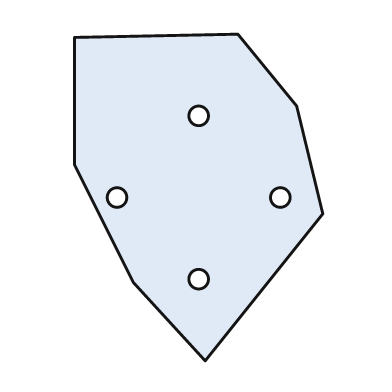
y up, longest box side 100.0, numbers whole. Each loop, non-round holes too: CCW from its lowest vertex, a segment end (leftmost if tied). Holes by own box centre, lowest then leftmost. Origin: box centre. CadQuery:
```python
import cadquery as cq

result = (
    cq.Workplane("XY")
    .moveTo(2.0, -50.0)
    .lineTo(38.0, -5.0)
    .lineTo(30.0, 28.0)
    .lineTo(12.0, 50.0)
    .lineTo(-38.0, 49.0)
    .lineTo(-38.0, 10.0)
    .lineTo(-20.0, -26.0)
    .close()
    .moveTo(0.0, -25.0)
    .circle(3.0)
    .moveTo(-25.0, 0.0)
    .circle(3.0)
    .moveTo(25.0, 0.0)
    .circle(3.0)
    .moveTo(0.0, 25.0)
    .circle(3.0)
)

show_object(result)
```